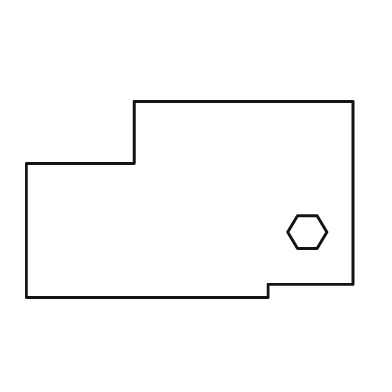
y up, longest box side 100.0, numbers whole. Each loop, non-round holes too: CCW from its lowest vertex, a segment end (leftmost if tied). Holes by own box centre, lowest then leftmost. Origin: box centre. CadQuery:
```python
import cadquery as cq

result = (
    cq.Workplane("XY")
    .moveTo(-50.0, -30.0)
    .lineTo(24.0, -30.0)
    .lineTo(24.0, -26.0)
    .lineTo(50.0, -26.0)
    .lineTo(50.0, 30.0)
    .lineTo(-17.0, 30.0)
    .lineTo(-17.0, 11.0)
    .lineTo(-50.0, 11.0)
    .close()
    .moveTo(33.0, -15.0)
    .lineTo(39.0, -15.0)
    .lineTo(42.0, -10.0)
    .lineTo(39.0, -5.0)
    .lineTo(33.0, -5.0)
    .lineTo(30.0, -10.0)
    .close()
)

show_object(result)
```